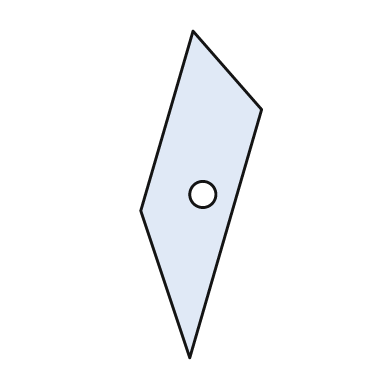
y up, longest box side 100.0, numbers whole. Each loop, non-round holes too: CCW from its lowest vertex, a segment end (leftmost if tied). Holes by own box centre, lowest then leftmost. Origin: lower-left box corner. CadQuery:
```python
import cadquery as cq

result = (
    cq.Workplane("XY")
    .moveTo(15.0, 0.0)
    .lineTo(37.0, 76.0)
    .lineTo(16.0, 100.0)
    .lineTo(0.0, 45.0)
    .close()
    .moveTo(19.0, 50.0)
    .circle(4.0)
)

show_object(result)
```